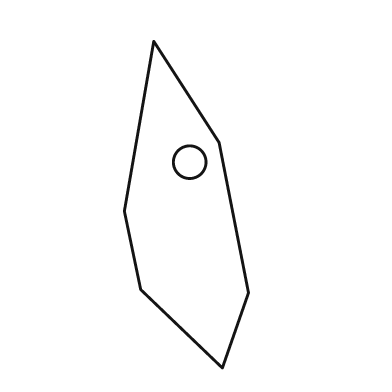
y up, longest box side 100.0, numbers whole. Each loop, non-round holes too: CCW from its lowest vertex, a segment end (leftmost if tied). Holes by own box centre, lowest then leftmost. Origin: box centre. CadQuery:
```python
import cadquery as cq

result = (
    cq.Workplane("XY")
    .moveTo(11.0, -50.0)
    .lineTo(19.0, -27.0)
    .lineTo(10.0, 19.0)
    .lineTo(-10.0, 50.0)
    .lineTo(-19.0, -2.0)
    .lineTo(-14.0, -26.0)
    .close()
    .moveTo(1.0, 13.0)
    .circle(5.0)
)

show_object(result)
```